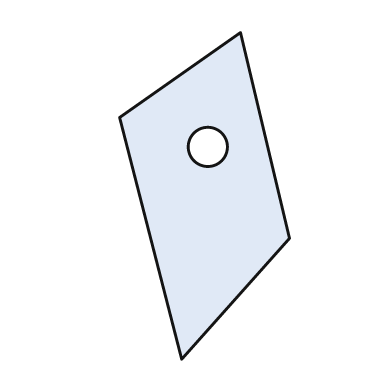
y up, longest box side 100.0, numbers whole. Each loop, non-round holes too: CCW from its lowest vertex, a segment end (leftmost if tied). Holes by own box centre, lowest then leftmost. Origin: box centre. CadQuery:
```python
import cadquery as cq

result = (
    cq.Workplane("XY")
    .moveTo(-7.0, -50.0)
    .lineTo(26.0, -13.0)
    .lineTo(11.0, 50.0)
    .lineTo(-26.0, 24.0)
    .close()
    .moveTo(1.0, 15.0)
    .circle(6.0)
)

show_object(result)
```